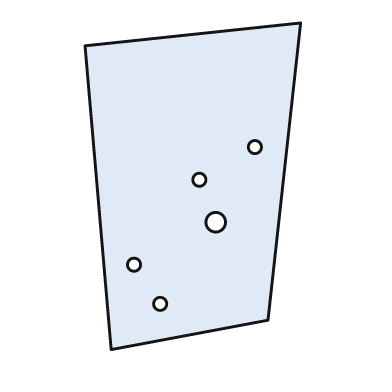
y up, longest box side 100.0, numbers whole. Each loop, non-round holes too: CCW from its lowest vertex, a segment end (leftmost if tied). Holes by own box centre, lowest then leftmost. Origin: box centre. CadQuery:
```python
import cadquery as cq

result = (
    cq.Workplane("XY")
    .moveTo(-25.0, -50.0)
    .lineTo(23.0, -41.0)
    .lineTo(33.0, 50.0)
    .lineTo(-33.0, 43.0)
    .close()
    .moveTo(-10.0, -36.0)
    .circle(2.0)
    .moveTo(-18.0, -24.0)
    .circle(2.0)
    .moveTo(7.0, -11.0)
    .circle(3.0)
    .moveTo(2.0, 2.0)
    .circle(2.0)
    .moveTo(19.0, 12.0)
    .circle(2.0)
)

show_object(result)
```